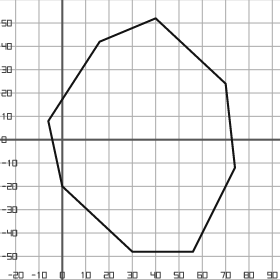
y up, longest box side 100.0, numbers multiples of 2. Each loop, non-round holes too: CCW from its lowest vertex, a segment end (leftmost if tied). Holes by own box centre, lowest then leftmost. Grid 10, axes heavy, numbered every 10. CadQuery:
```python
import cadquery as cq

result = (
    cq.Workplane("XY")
    .moveTo(30.0, -48.0)
    .lineTo(56.0, -48.0)
    .lineTo(74.0, -12.0)
    .lineTo(70.0, 24.0)
    .lineTo(40.0, 52.0)
    .lineTo(16.0, 42.0)
    .lineTo(-6.0, 8.0)
    .lineTo(0.0, -20.0)
    .close()
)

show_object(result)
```